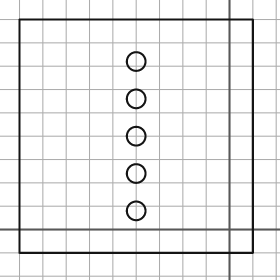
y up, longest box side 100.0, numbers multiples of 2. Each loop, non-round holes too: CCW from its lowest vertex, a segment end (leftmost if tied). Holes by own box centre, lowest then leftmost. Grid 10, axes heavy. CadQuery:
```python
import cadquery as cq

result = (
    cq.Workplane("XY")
    .moveTo(-90.0, -10.0)
    .lineTo(10.0, -10.0)
    .lineTo(10.0, 90.0)
    .lineTo(-90.0, 90.0)
    .close()
    .moveTo(-40.0, 8.0)
    .circle(4.0)
    .moveTo(-40.0, 24.0)
    .circle(4.0)
    .moveTo(-40.0, 40.0)
    .circle(4.0)
    .moveTo(-40.0, 56.0)
    .circle(4.0)
    .moveTo(-40.0, 72.0)
    .circle(4.0)
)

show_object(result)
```